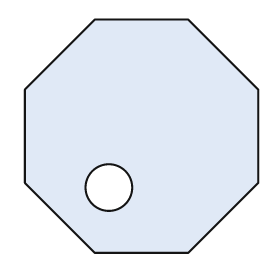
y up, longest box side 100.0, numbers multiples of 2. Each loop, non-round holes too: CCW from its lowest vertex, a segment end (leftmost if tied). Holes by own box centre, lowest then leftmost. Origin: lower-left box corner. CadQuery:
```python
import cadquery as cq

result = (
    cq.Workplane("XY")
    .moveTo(30.0, 0.0)
    .lineTo(70.0, 0.0)
    .lineTo(100.0, 30.0)
    .lineTo(100.0, 70.0)
    .lineTo(70.0, 100.0)
    .lineTo(30.0, 100.0)
    .lineTo(0.0, 70.0)
    .lineTo(0.0, 30.0)
    .close()
    .moveTo(36.0, 28.0)
    .circle(10.0)
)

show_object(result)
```